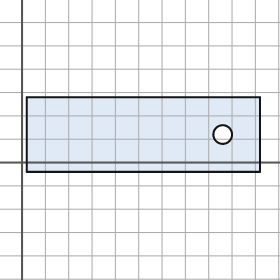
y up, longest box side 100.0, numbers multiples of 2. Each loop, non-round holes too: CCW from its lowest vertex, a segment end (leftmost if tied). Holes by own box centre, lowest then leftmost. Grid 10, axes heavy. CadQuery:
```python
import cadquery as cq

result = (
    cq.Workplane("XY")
    .moveTo(2.0, -4.0)
    .lineTo(102.0, -4.0)
    .lineTo(102.0, 28.0)
    .lineTo(2.0, 28.0)
    .close()
    .moveTo(86.0, 12.0)
    .circle(4.0)
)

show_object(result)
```